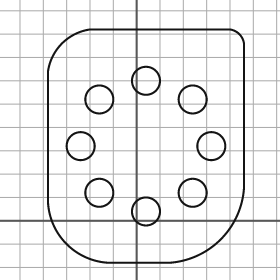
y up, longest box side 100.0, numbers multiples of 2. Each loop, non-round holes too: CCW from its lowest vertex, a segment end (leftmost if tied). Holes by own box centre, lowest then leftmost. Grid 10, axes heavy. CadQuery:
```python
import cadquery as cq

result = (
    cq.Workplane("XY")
    .moveTo(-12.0, -18.0)
    .lineTo(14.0, -18.0)
    .threePointArc((36.0, -8.0), (46.0, 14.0))
    .lineTo(46.0, 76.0)
    .threePointArc((44.0, 80.0), (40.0, 82.0))
    .lineTo(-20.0, 82.0)
    .threePointArc((-32.0, 76.0), (-38.0, 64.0))
    .lineTo(-38.0, 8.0)
    .threePointArc((-30.0, -10.0), (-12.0, -18.0))
    .close()
    .moveTo(4.0, 4.0)
    .circle(6.0)
    .moveTo(-16.0, 12.0)
    .circle(6.0)
    .moveTo(24.0, 12.0)
    .circle(6.0)
    .moveTo(-24.0, 32.0)
    .circle(6.0)
    .moveTo(32.0, 32.0)
    .circle(6.0)
    .moveTo(-16.0, 52.0)
    .circle(6.0)
    .moveTo(24.0, 52.0)
    .circle(6.0)
    .moveTo(4.0, 60.0)
    .circle(6.0)
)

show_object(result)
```